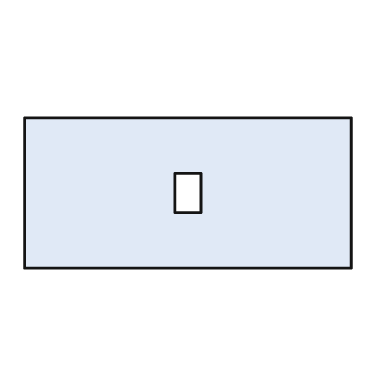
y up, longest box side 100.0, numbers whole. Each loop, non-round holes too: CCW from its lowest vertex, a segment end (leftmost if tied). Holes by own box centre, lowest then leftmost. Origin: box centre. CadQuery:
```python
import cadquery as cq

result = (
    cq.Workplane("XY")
    .moveTo(-50.0, -23.0)
    .lineTo(50.0, -23.0)
    .lineTo(50.0, 23.0)
    .lineTo(-50.0, 23.0)
    .close()
    .moveTo(-4.0, -6.0)
    .lineTo(4.0, -6.0)
    .lineTo(4.0, 6.0)
    .lineTo(-4.0, 6.0)
    .close()
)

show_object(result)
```